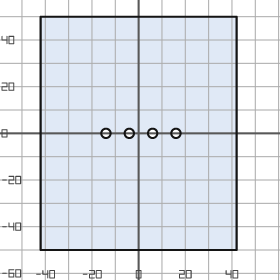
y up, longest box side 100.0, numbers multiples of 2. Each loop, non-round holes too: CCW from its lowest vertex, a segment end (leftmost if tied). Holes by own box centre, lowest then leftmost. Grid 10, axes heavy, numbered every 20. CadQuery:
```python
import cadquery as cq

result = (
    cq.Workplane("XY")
    .moveTo(-42.0, -50.0)
    .lineTo(42.0, -50.0)
    .lineTo(42.0, 50.0)
    .lineTo(-42.0, 50.0)
    .close()
    .moveTo(-14.0, 0.0)
    .circle(2.0)
    .moveTo(-4.0, 0.0)
    .circle(2.0)
    .moveTo(6.0, 0.0)
    .circle(2.0)
    .moveTo(16.0, 0.0)
    .circle(2.0)
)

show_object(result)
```